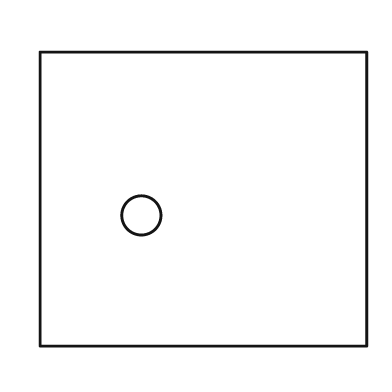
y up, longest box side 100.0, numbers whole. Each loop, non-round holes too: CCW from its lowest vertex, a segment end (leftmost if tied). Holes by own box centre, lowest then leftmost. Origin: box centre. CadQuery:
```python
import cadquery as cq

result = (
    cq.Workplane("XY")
    .moveTo(-50.0, -45.0)
    .lineTo(50.0, -45.0)
    .lineTo(50.0, 45.0)
    .lineTo(-50.0, 45.0)
    .close()
    .moveTo(-19.0, -5.0)
    .circle(6.0)
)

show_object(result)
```